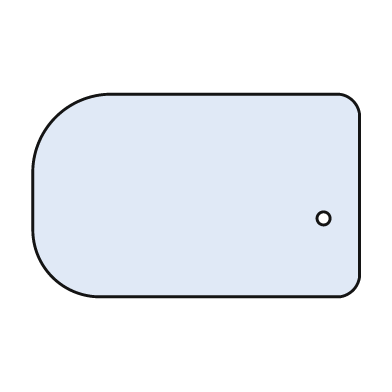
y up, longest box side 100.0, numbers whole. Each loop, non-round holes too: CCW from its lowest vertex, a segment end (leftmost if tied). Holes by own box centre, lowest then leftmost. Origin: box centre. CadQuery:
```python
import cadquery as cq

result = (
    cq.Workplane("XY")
    .moveTo(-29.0, -31.0)
    .lineTo(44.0, -31.0)
    .threePointArc((48.0, -29.0), (50.0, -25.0))
    .lineTo(50.0, 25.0)
    .threePointArc((48.0, 29.0), (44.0, 31.0))
    .lineTo(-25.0, 31.0)
    .threePointArc((-43.0, 24.0), (-50.0, 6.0))
    .lineTo(-50.0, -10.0)
    .threePointArc((-44.0, -25.0), (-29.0, -31.0))
    .close()
    .moveTo(39.0, -7.0)
    .circle(2.0)
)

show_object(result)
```